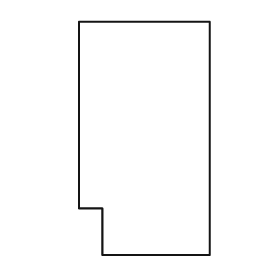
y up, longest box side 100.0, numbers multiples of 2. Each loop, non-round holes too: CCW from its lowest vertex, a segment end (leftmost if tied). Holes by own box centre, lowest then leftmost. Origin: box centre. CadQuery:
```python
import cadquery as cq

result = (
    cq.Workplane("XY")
    .moveTo(-18.0, -50.0)
    .lineTo(28.0, -50.0)
    .lineTo(28.0, 50.0)
    .lineTo(-28.0, 50.0)
    .lineTo(-28.0, -30.0)
    .lineTo(-18.0, -30.0)
    .close()
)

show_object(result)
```